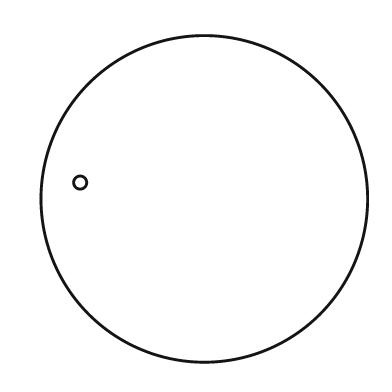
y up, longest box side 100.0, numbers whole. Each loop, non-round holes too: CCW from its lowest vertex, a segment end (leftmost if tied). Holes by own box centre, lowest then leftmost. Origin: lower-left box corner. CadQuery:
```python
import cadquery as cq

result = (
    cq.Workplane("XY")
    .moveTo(50.0, 50.0)
    .circle(50.0)
    .moveTo(12.0, 55.0)
    .circle(2.0)
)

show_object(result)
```